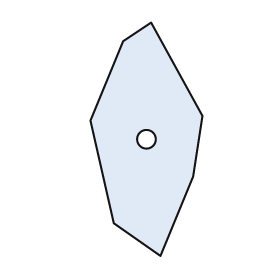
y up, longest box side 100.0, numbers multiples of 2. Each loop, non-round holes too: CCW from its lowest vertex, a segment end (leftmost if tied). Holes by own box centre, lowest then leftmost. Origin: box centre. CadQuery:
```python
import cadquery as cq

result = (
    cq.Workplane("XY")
    .moveTo(6.0, -50.0)
    .lineTo(20.0, -16.0)
    .lineTo(24.0, 10.0)
    .lineTo(2.0, 50.0)
    .lineTo(-10.0, 42.0)
    .lineTo(-24.0, 8.0)
    .lineTo(-14.0, -36.0)
    .close()
    .moveTo(0.0, 0.0)
    .circle(4.0)
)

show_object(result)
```